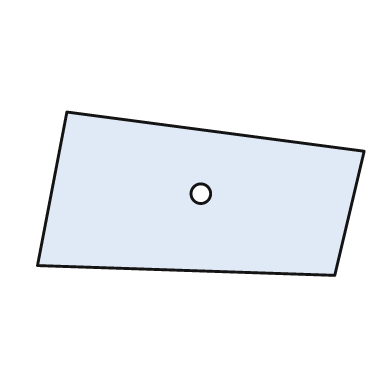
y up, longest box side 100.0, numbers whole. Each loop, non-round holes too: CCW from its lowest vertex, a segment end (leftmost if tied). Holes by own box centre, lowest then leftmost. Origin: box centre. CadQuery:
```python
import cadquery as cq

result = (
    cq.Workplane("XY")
    .moveTo(41.0, -25.0)
    .lineTo(50.0, 13.0)
    .lineTo(-41.0, 25.0)
    .lineTo(-50.0, -22.0)
    .close()
    .moveTo(0.0, 0.0)
    .circle(3.0)
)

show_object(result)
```